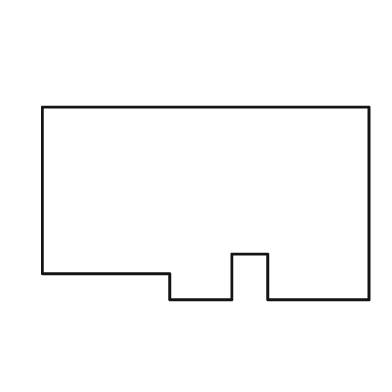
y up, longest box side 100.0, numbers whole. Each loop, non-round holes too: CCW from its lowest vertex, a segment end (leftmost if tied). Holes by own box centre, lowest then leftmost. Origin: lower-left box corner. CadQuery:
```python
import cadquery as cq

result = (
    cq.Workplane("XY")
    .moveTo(39.0, 0.0)
    .lineTo(58.0, 0.0)
    .lineTo(58.0, 14.0)
    .lineTo(69.0, 14.0)
    .lineTo(69.0, 0.0)
    .lineTo(100.0, 0.0)
    .lineTo(100.0, 59.0)
    .lineTo(0.0, 59.0)
    .lineTo(0.0, 8.0)
    .lineTo(39.0, 8.0)
    .close()
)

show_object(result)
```